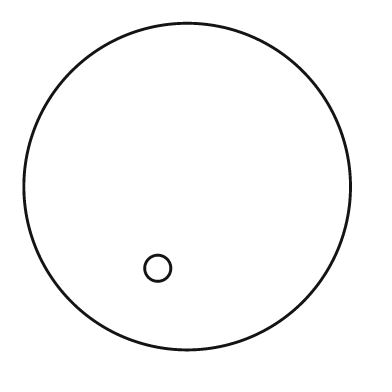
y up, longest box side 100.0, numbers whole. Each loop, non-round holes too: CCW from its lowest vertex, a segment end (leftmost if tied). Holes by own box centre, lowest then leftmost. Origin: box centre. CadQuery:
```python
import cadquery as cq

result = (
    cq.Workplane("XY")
    .moveTo(0.0, 0.0)
    .circle(50.0)
    .moveTo(-9.0, -25.0)
    .circle(4.0)
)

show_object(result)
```